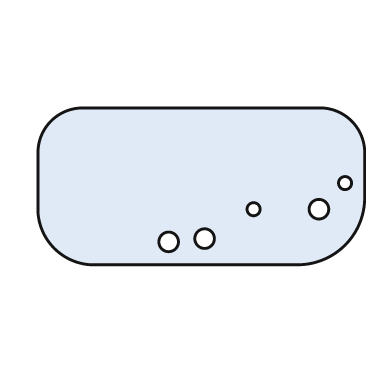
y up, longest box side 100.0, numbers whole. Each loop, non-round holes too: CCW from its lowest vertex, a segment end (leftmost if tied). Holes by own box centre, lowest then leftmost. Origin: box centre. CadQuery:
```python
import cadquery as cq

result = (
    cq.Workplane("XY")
    .moveTo(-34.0, -24.0)
    .lineTo(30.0, -24.0)
    .threePointArc((44.0, -18.0), (50.0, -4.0))
    .lineTo(50.0, 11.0)
    .threePointArc((46.0, 20.0), (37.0, 24.0))
    .lineTo(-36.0, 24.0)
    .threePointArc((-46.0, 20.0), (-50.0, 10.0))
    .lineTo(-50.0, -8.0)
    .threePointArc((-45.0, -19.0), (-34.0, -24.0))
    .close()
    .moveTo(-10.0, -17.0)
    .circle(3.0)
    .moveTo(1.0, -16.0)
    .circle(3.0)
    .moveTo(16.0, -7.0)
    .circle(2.0)
    .moveTo(36.0, -7.0)
    .circle(3.0)
    .moveTo(44.0, 1.0)
    .circle(2.0)
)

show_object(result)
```